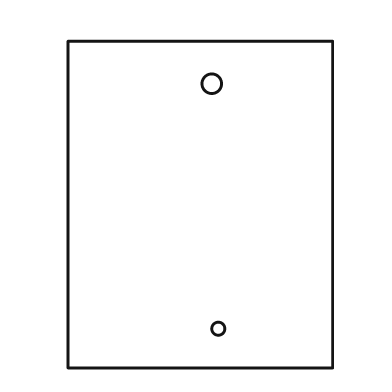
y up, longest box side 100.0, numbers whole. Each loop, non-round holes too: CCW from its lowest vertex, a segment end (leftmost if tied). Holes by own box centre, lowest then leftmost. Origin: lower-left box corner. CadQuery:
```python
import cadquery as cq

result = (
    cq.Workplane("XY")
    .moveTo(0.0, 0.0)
    .lineTo(81.0, 0.0)
    .lineTo(81.0, 100.0)
    .lineTo(0.0, 100.0)
    .close()
    .moveTo(46.0, 12.0)
    .circle(2.0)
    .moveTo(44.0, 87.0)
    .circle(3.0)
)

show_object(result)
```